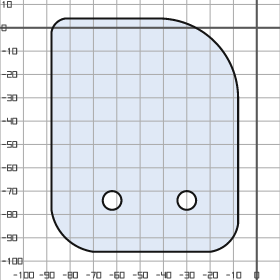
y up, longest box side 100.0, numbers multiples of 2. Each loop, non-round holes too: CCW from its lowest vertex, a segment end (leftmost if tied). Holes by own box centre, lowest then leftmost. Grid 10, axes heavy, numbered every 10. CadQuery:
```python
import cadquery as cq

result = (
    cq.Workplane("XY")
    .moveTo(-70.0, -96.0)
    .lineTo(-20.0, -96.0)
    .threePointArc((-12.0, -92.0), (-8.0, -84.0))
    .lineTo(-8.0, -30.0)
    .threePointArc((-18.0, -6.0), (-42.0, 4.0))
    .lineTo(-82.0, 4.0)
    .threePointArc((-86.0, 2.0), (-88.0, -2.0))
    .lineTo(-88.0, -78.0)
    .threePointArc((-82.0, -90.0), (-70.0, -96.0))
    .close()
    .moveTo(-62.0, -74.0)
    .circle(4.0)
    .moveTo(-30.0, -74.0)
    .circle(4.0)
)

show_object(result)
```